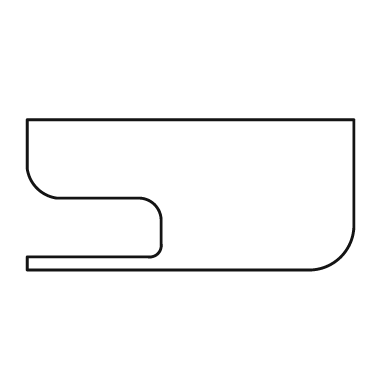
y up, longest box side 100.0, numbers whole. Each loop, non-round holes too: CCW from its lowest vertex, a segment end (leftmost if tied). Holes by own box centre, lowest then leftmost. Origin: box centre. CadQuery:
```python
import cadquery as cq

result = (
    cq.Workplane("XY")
    .moveTo(-50.0, -23.0)
    .lineTo(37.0, -23.0)
    .threePointArc((46.0, -19.0), (50.0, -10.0))
    .lineTo(50.0, 23.0)
    .lineTo(-50.0, 23.0)
    .lineTo(-50.0, 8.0)
    .threePointArc((-47.0, 2.0), (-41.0, -1.0))
    .lineTo(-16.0, -1.0)
    .threePointArc((-11.0, -3.0), (-9.0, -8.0))
    .lineTo(-9.0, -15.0)
    .threePointArc((-10.0, -18.0), (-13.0, -19.0))
    .lineTo(-50.0, -19.0)
    .close()
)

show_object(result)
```